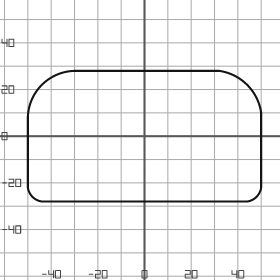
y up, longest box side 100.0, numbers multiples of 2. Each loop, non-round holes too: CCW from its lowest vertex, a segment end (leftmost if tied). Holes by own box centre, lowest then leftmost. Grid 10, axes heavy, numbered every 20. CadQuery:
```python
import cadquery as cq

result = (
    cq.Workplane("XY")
    .moveTo(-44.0, -28.0)
    .lineTo(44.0, -28.0)
    .threePointArc((48.0, -26.0), (50.0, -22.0))
    .lineTo(50.0, 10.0)
    .threePointArc((44.0, 22.0), (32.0, 28.0))
    .lineTo(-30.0, 28.0)
    .threePointArc((-44.0, 22.0), (-50.0, 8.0))
    .lineTo(-50.0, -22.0)
    .threePointArc((-48.0, -26.0), (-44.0, -28.0))
    .close()
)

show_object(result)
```